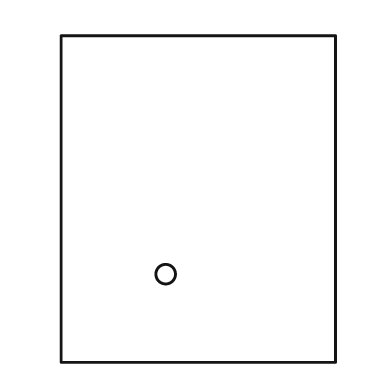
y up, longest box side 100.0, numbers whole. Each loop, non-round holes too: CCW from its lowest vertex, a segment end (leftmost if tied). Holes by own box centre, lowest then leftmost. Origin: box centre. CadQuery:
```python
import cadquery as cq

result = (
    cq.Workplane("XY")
    .moveTo(-42.0, -50.0)
    .lineTo(42.0, -50.0)
    .lineTo(42.0, 50.0)
    .lineTo(-42.0, 50.0)
    .close()
    .moveTo(-10.0, -23.0)
    .circle(3.0)
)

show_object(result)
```